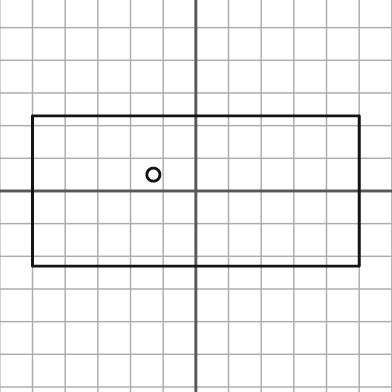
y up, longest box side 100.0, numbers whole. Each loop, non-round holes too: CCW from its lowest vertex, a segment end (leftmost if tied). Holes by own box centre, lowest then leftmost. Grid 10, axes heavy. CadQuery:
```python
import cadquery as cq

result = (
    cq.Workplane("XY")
    .moveTo(-50.0, -23.0)
    .lineTo(50.0, -23.0)
    .lineTo(50.0, 23.0)
    .lineTo(-50.0, 23.0)
    .close()
    .moveTo(-13.0, 5.0)
    .circle(2.0)
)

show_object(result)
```